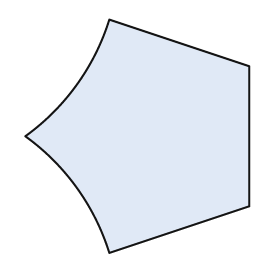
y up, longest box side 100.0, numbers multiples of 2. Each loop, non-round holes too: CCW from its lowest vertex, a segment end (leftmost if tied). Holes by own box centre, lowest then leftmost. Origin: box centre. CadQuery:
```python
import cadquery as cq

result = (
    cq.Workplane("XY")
    .moveTo(-12.0, -50.0)
    .lineTo(48.0, -30.0)
    .lineTo(48.0, 30.0)
    .lineTo(-12.0, 50.0)
    .threePointArc((-26.0, 22.0), (-48.0, 0.0))
    .threePointArc((-26.0, -22.0), (-12.0, -50.0))
    .close()
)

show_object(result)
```